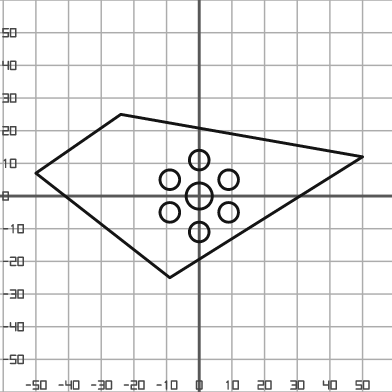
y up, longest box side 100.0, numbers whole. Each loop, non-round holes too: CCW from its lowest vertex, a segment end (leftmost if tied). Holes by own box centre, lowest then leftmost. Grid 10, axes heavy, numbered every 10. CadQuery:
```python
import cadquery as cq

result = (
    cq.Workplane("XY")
    .moveTo(-9.0, -25.0)
    .lineTo(50.0, 12.0)
    .lineTo(-24.0, 25.0)
    .lineTo(-50.0, 7.0)
    .close()
    .moveTo(0.0, -11.0)
    .circle(3.0)
    .moveTo(-9.0, -5.0)
    .circle(3.0)
    .moveTo(9.0, -5.0)
    .circle(3.0)
    .moveTo(0.0, 0.0)
    .circle(4.0)
    .moveTo(-9.0, 5.0)
    .circle(3.0)
    .moveTo(9.0, 5.0)
    .circle(3.0)
    .moveTo(0.0, 11.0)
    .circle(3.0)
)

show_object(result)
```